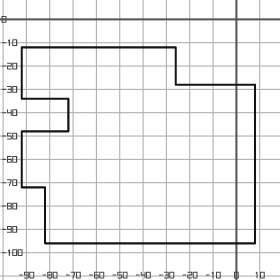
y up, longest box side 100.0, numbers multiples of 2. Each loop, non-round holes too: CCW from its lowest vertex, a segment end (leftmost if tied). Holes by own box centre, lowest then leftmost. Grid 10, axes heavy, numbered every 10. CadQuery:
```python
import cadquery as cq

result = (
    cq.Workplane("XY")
    .moveTo(-82.0, -96.0)
    .lineTo(8.0, -96.0)
    .lineTo(8.0, -28.0)
    .lineTo(-26.0, -28.0)
    .lineTo(-26.0, -12.0)
    .lineTo(-92.0, -12.0)
    .lineTo(-92.0, -34.0)
    .lineTo(-72.0, -34.0)
    .lineTo(-72.0, -48.0)
    .lineTo(-92.0, -48.0)
    .lineTo(-92.0, -72.0)
    .lineTo(-82.0, -72.0)
    .close()
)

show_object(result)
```